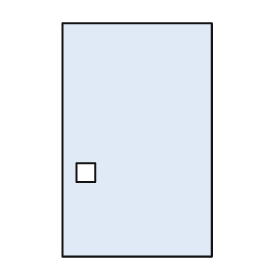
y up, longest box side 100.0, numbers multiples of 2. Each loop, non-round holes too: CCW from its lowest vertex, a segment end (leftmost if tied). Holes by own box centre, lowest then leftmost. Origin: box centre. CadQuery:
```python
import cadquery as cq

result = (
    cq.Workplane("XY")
    .moveTo(-32.0, -50.0)
    .lineTo(32.0, -50.0)
    .lineTo(32.0, 50.0)
    .lineTo(-32.0, 50.0)
    .close()
    .moveTo(-26.0, -18.0)
    .lineTo(-18.0, -18.0)
    .lineTo(-18.0, -10.0)
    .lineTo(-26.0, -10.0)
    .close()
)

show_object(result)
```